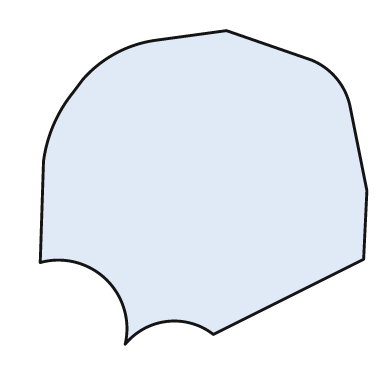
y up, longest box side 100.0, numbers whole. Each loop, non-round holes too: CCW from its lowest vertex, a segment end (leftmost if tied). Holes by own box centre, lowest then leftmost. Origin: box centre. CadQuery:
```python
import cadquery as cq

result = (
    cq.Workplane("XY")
    .moveTo(-24.0, -48.0)
    .threePointArc((-11.0, -41.0), (3.0, -45.0))
    .lineTo(49.0, -22.0)
    .lineTo(50.0, -1.0)
    .lineTo(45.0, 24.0)
    .threePointArc((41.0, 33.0), (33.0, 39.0))
    .lineTo(7.0, 48.0)
    .lineTo(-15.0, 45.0)
    .threePointArc((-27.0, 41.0), (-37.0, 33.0))
    .lineTo(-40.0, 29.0)
    .threePointArc((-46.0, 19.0), (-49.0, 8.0))
    .lineTo(-50.0, -23.0)
    .threePointArc((-30.0, -28.0), (-24.0, -48.0))
    .close()
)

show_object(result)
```